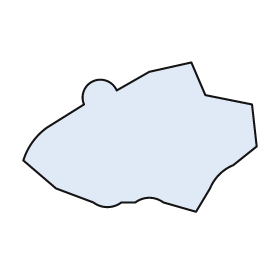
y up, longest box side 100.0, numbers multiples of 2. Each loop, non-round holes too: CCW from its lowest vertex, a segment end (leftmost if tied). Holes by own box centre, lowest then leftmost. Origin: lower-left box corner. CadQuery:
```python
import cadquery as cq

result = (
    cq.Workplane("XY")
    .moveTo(74.0, 0.0)
    .lineTo(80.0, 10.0)
    .threePointArc((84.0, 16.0), (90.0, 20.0))
    .lineTo(100.0, 28.0)
    .lineTo(98.0, 46.0)
    .lineTo(78.0, 50.0)
    .lineTo(72.0, 64.0)
    .lineTo(54.0, 60.0)
    .lineTo(40.0, 52.0)
    .threePointArc((30.0, 56.0), (26.0, 46.0))
    .lineTo(10.0, 36.0)
    .threePointArc((4.0, 30.0), (0.0, 22.0))
    .lineTo(14.0, 10.0)
    .lineTo(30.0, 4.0)
    .threePointArc((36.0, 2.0), (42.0, 4.0))
    .lineTo(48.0, 4.0)
    .threePointArc((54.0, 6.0), (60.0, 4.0))
    .close()
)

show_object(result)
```